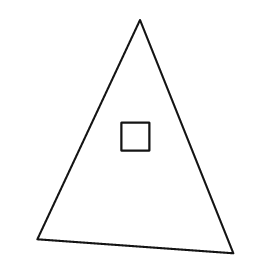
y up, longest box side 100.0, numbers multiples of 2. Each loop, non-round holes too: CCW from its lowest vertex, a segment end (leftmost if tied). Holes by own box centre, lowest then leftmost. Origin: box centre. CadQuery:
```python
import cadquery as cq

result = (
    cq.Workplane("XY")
    .moveTo(42.0, -50.0)
    .lineTo(2.0, 50.0)
    .lineTo(-42.0, -44.0)
    .close()
    .moveTo(-6.0, -6.0)
    .lineTo(6.0, -6.0)
    .lineTo(6.0, 6.0)
    .lineTo(-6.0, 6.0)
    .close()
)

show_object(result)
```